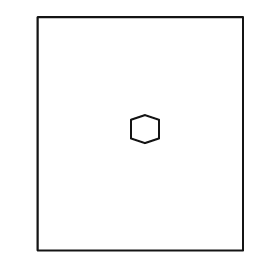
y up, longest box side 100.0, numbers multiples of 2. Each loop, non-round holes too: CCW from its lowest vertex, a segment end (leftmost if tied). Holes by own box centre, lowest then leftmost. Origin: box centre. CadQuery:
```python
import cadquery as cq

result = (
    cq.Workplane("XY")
    .moveTo(-44.0, -50.0)
    .lineTo(44.0, -50.0)
    .lineTo(44.0, 50.0)
    .lineTo(-44.0, 50.0)
    .close()
    .moveTo(2.0, -4.0)
    .lineTo(8.0, -2.0)
    .lineTo(8.0, 6.0)
    .lineTo(2.0, 8.0)
    .lineTo(-4.0, 6.0)
    .lineTo(-4.0, -2.0)
    .close()
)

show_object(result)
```